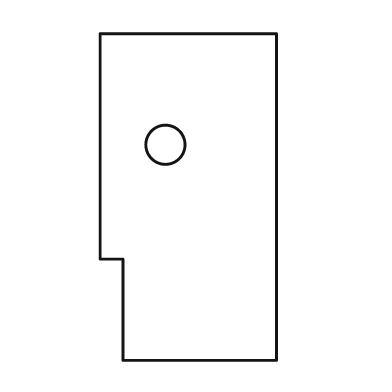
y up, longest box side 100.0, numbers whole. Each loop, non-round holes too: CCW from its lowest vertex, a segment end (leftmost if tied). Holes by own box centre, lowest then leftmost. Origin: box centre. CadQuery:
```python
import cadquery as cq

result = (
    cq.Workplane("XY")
    .moveTo(-20.0, -50.0)
    .lineTo(27.0, -50.0)
    .lineTo(27.0, 50.0)
    .lineTo(-27.0, 50.0)
    .lineTo(-27.0, -19.0)
    .lineTo(-20.0, -19.0)
    .close()
    .moveTo(-7.0, 16.0)
    .circle(6.0)
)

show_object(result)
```